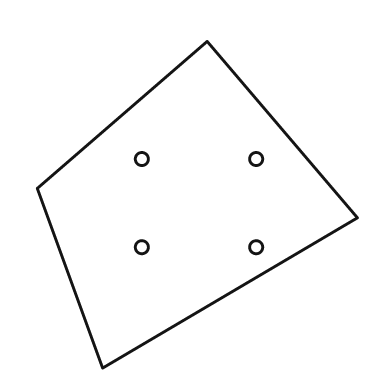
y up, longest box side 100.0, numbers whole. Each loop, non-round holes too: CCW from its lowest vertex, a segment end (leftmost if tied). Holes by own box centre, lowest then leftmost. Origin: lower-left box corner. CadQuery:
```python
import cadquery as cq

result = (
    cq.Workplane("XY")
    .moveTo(20.0, 0.0)
    .lineTo(98.0, 46.0)
    .lineTo(52.0, 100.0)
    .lineTo(0.0, 55.0)
    .close()
    .moveTo(32.0, 37.0)
    .circle(2.0)
    .moveTo(67.0, 37.0)
    .circle(2.0)
    .moveTo(32.0, 64.0)
    .circle(2.0)
    .moveTo(67.0, 64.0)
    .circle(2.0)
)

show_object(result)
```